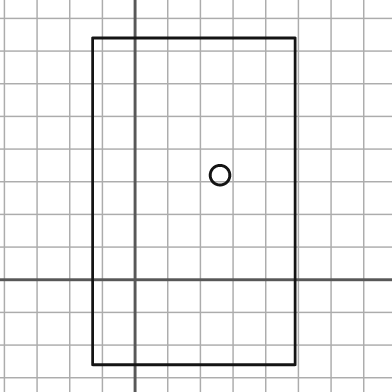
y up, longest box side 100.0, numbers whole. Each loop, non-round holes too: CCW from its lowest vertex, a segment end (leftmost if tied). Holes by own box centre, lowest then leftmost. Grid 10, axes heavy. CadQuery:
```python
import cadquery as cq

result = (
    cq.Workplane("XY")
    .moveTo(-13.0, -26.0)
    .lineTo(49.0, -26.0)
    .lineTo(49.0, 74.0)
    .lineTo(-13.0, 74.0)
    .close()
    .moveTo(26.0, 32.0)
    .circle(3.0)
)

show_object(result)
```